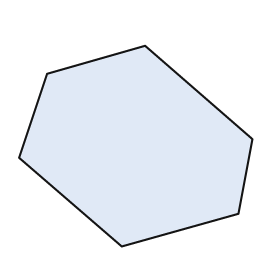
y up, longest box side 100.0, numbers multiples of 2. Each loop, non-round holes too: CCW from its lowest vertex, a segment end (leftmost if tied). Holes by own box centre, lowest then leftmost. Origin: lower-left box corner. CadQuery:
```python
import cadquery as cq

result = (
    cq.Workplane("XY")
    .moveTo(44.0, 0.0)
    .lineTo(94.0, 14.0)
    .lineTo(100.0, 46.0)
    .lineTo(54.0, 86.0)
    .lineTo(12.0, 74.0)
    .lineTo(0.0, 38.0)
    .close()
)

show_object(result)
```